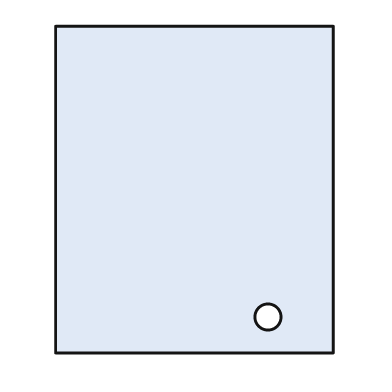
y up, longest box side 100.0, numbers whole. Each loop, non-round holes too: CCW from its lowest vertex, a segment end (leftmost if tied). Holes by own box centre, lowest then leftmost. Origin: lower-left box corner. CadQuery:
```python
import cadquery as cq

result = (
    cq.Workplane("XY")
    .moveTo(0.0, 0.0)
    .lineTo(85.0, 0.0)
    .lineTo(85.0, 100.0)
    .lineTo(0.0, 100.0)
    .close()
    .moveTo(65.0, 11.0)
    .circle(4.0)
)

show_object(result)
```